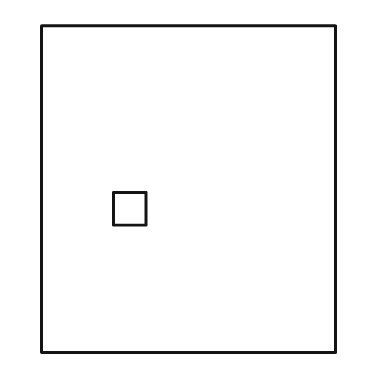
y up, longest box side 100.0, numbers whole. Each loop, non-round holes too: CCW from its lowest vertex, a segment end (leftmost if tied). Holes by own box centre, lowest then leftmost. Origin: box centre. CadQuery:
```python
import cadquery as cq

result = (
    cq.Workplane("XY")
    .moveTo(-45.0, -50.0)
    .lineTo(45.0, -50.0)
    .lineTo(45.0, 50.0)
    .lineTo(-45.0, 50.0)
    .close()
    .moveTo(-23.0, -11.0)
    .lineTo(-13.0, -11.0)
    .lineTo(-13.0, -1.0)
    .lineTo(-23.0, -1.0)
    .close()
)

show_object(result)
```